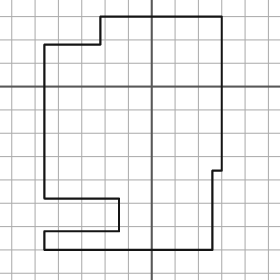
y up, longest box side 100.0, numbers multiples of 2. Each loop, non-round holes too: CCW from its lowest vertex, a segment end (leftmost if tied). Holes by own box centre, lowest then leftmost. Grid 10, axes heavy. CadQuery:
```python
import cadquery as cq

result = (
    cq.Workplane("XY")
    .moveTo(-46.0, -70.0)
    .lineTo(26.0, -70.0)
    .lineTo(26.0, -36.0)
    .lineTo(30.0, -36.0)
    .lineTo(30.0, 30.0)
    .lineTo(-22.0, 30.0)
    .lineTo(-22.0, 18.0)
    .lineTo(-46.0, 18.0)
    .lineTo(-46.0, -48.0)
    .lineTo(-14.0, -48.0)
    .lineTo(-14.0, -62.0)
    .lineTo(-46.0, -62.0)
    .close()
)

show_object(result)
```